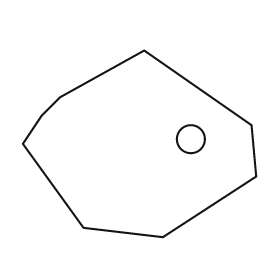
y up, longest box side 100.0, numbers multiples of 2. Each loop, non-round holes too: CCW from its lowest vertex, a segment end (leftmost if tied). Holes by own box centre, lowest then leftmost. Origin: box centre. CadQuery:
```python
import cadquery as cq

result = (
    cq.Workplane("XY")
    .moveTo(10.0, -40.0)
    .lineTo(50.0, -14.0)
    .lineTo(48.0, 8.0)
    .lineTo(2.0, 40.0)
    .lineTo(-34.0, 20.0)
    .lineTo(-42.0, 12.0)
    .lineTo(-50.0, 0.0)
    .lineTo(-24.0, -36.0)
    .close()
    .moveTo(22.0, 2.0)
    .circle(6.0)
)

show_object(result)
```